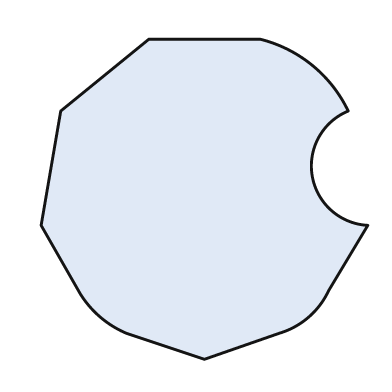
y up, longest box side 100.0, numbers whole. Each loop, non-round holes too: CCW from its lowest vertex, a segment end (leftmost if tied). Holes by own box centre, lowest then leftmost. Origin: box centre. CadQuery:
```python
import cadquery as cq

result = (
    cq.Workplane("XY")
    .moveTo(0.0, -49.0)
    .lineTo(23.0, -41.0)
    .threePointArc((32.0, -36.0), (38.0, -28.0))
    .lineTo(50.0, -8.0)
    .threePointArc((33.0, 7.0), (44.0, 27.0))
    .threePointArc((33.0, 41.0), (17.0, 49.0))
    .lineTo(-17.0, 49.0)
    .lineTo(-44.0, 27.0)
    .lineTo(-50.0, -8.0)
    .lineTo(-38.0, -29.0)
    .threePointArc((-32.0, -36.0), (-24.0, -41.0))
    .close()
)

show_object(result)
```